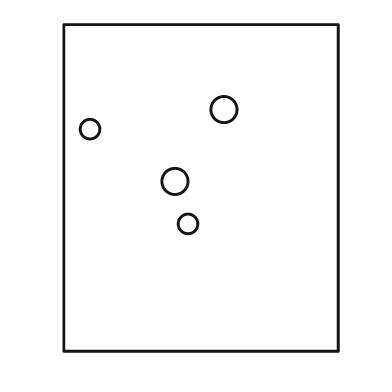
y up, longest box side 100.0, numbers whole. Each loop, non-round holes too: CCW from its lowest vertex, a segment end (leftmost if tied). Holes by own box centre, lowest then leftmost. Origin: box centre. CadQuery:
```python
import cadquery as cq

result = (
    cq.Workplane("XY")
    .moveTo(-42.0, -50.0)
    .lineTo(42.0, -50.0)
    .lineTo(42.0, 50.0)
    .lineTo(-42.0, 50.0)
    .close()
    .moveTo(-4.0, -11.0)
    .circle(3.0)
    .moveTo(-8.0, 2.0)
    .circle(4.0)
    .moveTo(-34.0, 18.0)
    .circle(3.0)
    .moveTo(7.0, 24.0)
    .circle(4.0)
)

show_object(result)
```